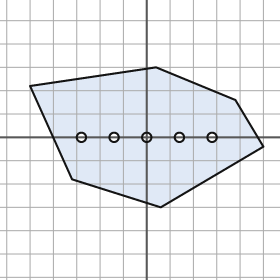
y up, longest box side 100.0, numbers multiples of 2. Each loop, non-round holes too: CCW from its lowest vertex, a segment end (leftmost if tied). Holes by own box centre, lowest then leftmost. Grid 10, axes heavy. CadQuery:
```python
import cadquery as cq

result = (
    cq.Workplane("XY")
    .moveTo(6.0, -30.0)
    .lineTo(50.0, -4.0)
    .lineTo(38.0, 16.0)
    .lineTo(4.0, 30.0)
    .lineTo(-50.0, 22.0)
    .lineTo(-32.0, -18.0)
    .close()
    .moveTo(-28.0, 0.0)
    .circle(2.0)
    .moveTo(-14.0, 0.0)
    .circle(2.0)
    .moveTo(0.0, 0.0)
    .circle(2.0)
    .moveTo(14.0, 0.0)
    .circle(2.0)
    .moveTo(28.0, 0.0)
    .circle(2.0)
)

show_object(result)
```